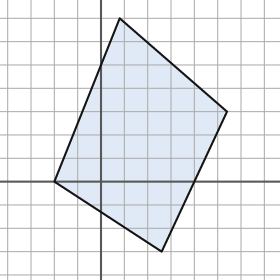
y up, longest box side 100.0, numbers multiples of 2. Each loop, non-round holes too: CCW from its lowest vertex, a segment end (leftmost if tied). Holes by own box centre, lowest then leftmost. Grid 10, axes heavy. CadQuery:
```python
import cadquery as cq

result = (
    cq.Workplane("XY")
    .moveTo(26.0, -30.0)
    .lineTo(54.0, 30.0)
    .lineTo(8.0, 70.0)
    .lineTo(-20.0, 0.0)
    .close()
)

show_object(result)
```